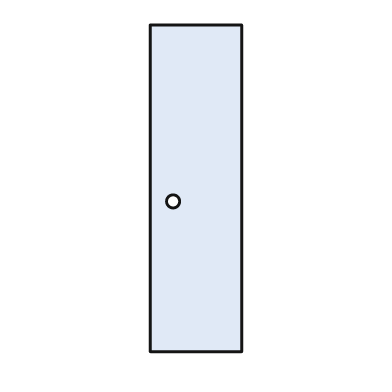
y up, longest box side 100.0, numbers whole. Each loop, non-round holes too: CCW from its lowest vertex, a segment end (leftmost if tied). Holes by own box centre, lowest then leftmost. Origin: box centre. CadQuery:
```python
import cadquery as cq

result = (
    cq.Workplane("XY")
    .moveTo(-14.0, -50.0)
    .lineTo(14.0, -50.0)
    .lineTo(14.0, 50.0)
    .lineTo(-14.0, 50.0)
    .close()
    .moveTo(-7.0, -4.0)
    .circle(2.0)
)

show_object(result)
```